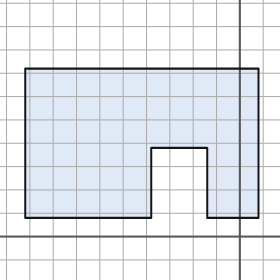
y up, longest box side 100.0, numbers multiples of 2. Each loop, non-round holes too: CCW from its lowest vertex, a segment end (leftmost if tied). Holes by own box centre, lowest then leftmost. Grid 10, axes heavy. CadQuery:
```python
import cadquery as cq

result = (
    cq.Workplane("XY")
    .moveTo(-92.0, 8.0)
    .lineTo(-38.0, 8.0)
    .lineTo(-38.0, 38.0)
    .lineTo(-14.0, 38.0)
    .lineTo(-14.0, 8.0)
    .lineTo(8.0, 8.0)
    .lineTo(8.0, 72.0)
    .lineTo(-92.0, 72.0)
    .close()
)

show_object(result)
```